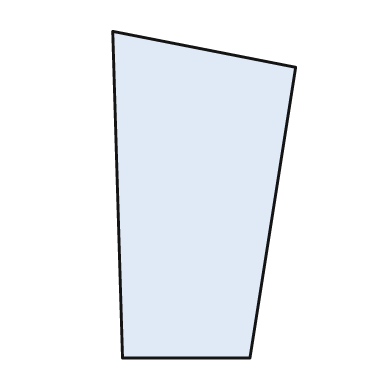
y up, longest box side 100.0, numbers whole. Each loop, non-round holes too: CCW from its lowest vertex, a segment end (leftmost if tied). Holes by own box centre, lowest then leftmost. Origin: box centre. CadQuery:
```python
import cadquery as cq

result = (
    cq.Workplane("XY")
    .moveTo(-25.0, -50.0)
    .lineTo(14.0, -50.0)
    .lineTo(28.0, 39.0)
    .lineTo(-28.0, 50.0)
    .close()
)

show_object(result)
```